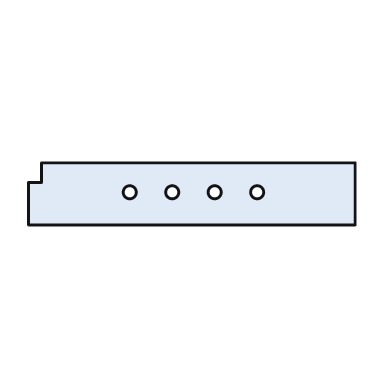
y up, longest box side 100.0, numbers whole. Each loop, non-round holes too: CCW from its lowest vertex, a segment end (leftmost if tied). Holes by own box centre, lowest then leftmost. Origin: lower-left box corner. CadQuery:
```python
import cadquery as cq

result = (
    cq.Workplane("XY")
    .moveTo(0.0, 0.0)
    .lineTo(100.0, 0.0)
    .lineTo(100.0, 19.0)
    .lineTo(4.0, 19.0)
    .lineTo(4.0, 13.0)
    .lineTo(0.0, 13.0)
    .close()
    .moveTo(31.0, 10.0)
    .circle(2.0)
    .moveTo(44.0, 10.0)
    .circle(2.0)
    .moveTo(57.0, 10.0)
    .circle(2.0)
    .moveTo(70.0, 10.0)
    .circle(2.0)
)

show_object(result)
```